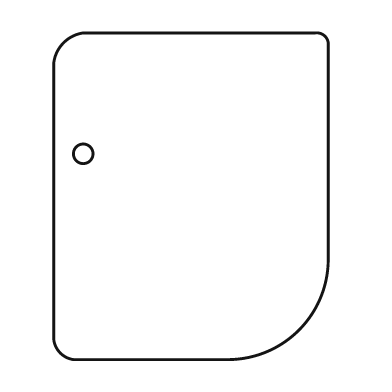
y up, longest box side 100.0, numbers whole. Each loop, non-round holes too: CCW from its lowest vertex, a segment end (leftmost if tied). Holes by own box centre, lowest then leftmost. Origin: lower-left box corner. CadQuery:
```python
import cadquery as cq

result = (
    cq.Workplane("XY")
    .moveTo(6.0, 0.0)
    .lineTo(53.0, 0.0)
    .threePointArc((75.0, 9.0), (84.0, 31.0))
    .lineTo(84.0, 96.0)
    .threePointArc((83.0, 99.0), (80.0, 100.0))
    .lineTo(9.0, 100.0)
    .threePointArc((3.0, 97.0), (0.0, 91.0))
    .lineTo(0.0, 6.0)
    .threePointArc((2.0, 2.0), (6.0, 0.0))
    .close()
    .moveTo(9.0, 63.0)
    .circle(3.0)
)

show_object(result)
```